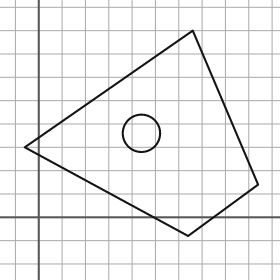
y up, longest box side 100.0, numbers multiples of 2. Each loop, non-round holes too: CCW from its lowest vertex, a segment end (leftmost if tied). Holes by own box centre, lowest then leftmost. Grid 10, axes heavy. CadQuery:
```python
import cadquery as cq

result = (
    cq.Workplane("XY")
    .moveTo(64.0, -8.0)
    .lineTo(94.0, 14.0)
    .lineTo(66.0, 80.0)
    .lineTo(-6.0, 30.0)
    .close()
    .moveTo(44.0, 36.0)
    .circle(8.0)
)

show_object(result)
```